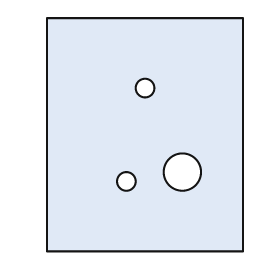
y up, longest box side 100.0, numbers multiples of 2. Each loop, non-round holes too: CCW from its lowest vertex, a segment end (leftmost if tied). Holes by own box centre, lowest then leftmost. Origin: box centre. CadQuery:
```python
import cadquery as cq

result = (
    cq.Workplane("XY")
    .moveTo(-42.0, -50.0)
    .lineTo(42.0, -50.0)
    .lineTo(42.0, 50.0)
    .lineTo(-42.0, 50.0)
    .close()
    .moveTo(-8.0, -20.0)
    .circle(4.0)
    .moveTo(16.0, -16.0)
    .circle(8.0)
    .moveTo(0.0, 20.0)
    .circle(4.0)
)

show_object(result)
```